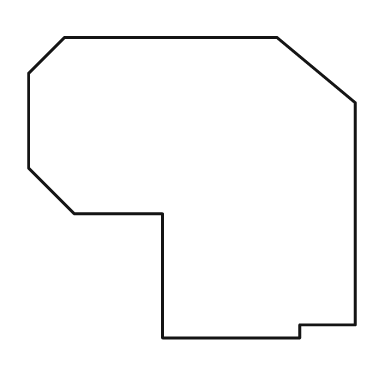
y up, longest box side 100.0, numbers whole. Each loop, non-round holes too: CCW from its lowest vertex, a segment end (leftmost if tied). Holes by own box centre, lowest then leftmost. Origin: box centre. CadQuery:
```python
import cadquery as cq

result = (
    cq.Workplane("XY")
    .moveTo(-9.0, -46.0)
    .lineTo(33.0, -46.0)
    .lineTo(33.0, -42.0)
    .lineTo(50.0, -42.0)
    .lineTo(50.0, 26.0)
    .lineTo(26.0, 46.0)
    .lineTo(-39.0, 46.0)
    .lineTo(-50.0, 35.0)
    .lineTo(-50.0, 6.0)
    .lineTo(-36.0, -8.0)
    .lineTo(-9.0, -8.0)
    .close()
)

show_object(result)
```